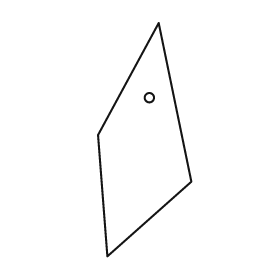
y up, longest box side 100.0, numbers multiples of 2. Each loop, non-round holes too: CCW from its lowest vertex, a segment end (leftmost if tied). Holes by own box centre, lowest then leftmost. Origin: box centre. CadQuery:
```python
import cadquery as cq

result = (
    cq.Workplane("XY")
    .moveTo(-16.0, -50.0)
    .lineTo(20.0, -18.0)
    .lineTo(6.0, 50.0)
    .lineTo(-20.0, 2.0)
    .close()
    .moveTo(2.0, 18.0)
    .circle(2.0)
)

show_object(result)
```